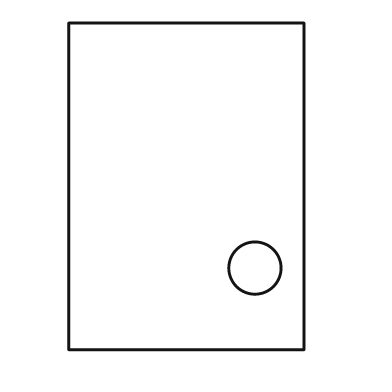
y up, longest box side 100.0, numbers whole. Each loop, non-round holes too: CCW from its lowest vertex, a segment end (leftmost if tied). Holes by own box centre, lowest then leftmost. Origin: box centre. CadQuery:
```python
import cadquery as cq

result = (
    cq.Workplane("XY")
    .moveTo(-36.0, -50.0)
    .lineTo(36.0, -50.0)
    .lineTo(36.0, 50.0)
    .lineTo(-36.0, 50.0)
    .close()
    .moveTo(21.0, -25.0)
    .circle(8.0)
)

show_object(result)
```